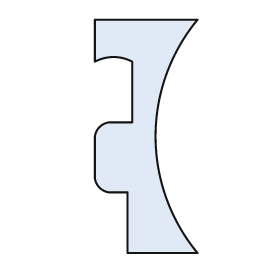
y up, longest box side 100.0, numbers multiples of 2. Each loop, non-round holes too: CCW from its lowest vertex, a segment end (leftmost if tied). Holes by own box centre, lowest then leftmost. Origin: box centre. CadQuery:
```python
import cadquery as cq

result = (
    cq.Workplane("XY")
    .moveTo(-8.0, -50.0)
    .lineTo(22.0, -50.0)
    .threePointArc((4.0, 0.0), (22.0, 50.0))
    .lineTo(-22.0, 50.0)
    .lineTo(-22.0, 32.0)
    .threePointArc((-14.0, 34.0), (-6.0, 32.0))
    .lineTo(-6.0, 6.0)
    .lineTo(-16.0, 6.0)
    .threePointArc((-20.0, 4.0), (-22.0, 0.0))
    .lineTo(-22.0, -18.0)
    .threePointArc((-20.0, -22.0), (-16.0, -24.0))
    .lineTo(-8.0, -24.0)
    .close()
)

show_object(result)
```